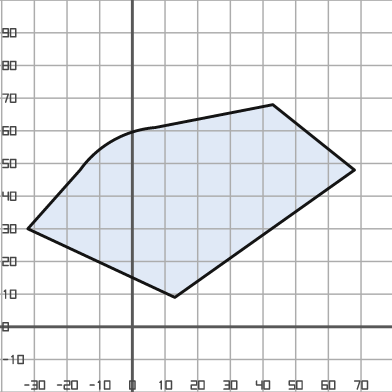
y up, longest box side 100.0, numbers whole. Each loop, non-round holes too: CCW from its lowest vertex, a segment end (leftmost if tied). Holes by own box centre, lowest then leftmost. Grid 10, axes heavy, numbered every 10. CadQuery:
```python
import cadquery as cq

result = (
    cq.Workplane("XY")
    .moveTo(13.0, 9.0)
    .lineTo(68.0, 48.0)
    .lineTo(43.0, 68.0)
    .lineTo(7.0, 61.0)
    .threePointArc((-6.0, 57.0), (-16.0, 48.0))
    .lineTo(-32.0, 30.0)
    .close()
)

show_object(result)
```